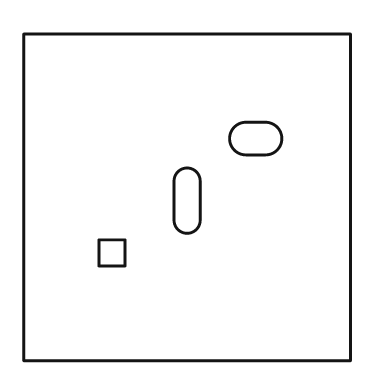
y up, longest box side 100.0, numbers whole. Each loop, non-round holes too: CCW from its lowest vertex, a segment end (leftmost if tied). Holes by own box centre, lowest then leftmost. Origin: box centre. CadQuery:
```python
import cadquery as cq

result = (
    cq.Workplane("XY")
    .moveTo(-50.0, -50.0)
    .lineTo(50.0, -50.0)
    .lineTo(50.0, 50.0)
    .lineTo(-50.0, 50.0)
    .close()
    .moveTo(-27.0, -21.0)
    .lineTo(-19.0, -21.0)
    .lineTo(-19.0, -13.0)
    .lineTo(-27.0, -13.0)
    .close()
    .moveTo(-4.0, -7.0)
    .threePointArc((0.0, -11.0), (4.0, -7.0))
    .lineTo(4.0, 5.0)
    .threePointArc((0.0, 9.0), (-4.0, 5.0))
    .close()
    .moveTo(18.0, 13.0)
    .lineTo(24.0, 13.0)
    .threePointArc((29.0, 18.0), (24.0, 23.0))
    .lineTo(18.0, 23.0)
    .threePointArc((13.0, 18.0), (18.0, 13.0))
    .close()
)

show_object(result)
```